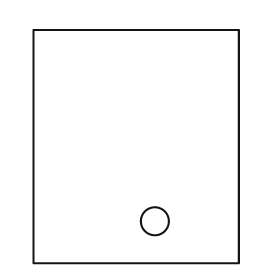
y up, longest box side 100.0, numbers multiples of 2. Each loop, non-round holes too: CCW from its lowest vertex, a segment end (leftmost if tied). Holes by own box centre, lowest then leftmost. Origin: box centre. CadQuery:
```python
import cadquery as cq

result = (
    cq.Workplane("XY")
    .moveTo(-44.0, -50.0)
    .lineTo(44.0, -50.0)
    .lineTo(44.0, 50.0)
    .lineTo(-44.0, 50.0)
    .close()
    .moveTo(8.0, -32.0)
    .circle(6.0)
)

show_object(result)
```